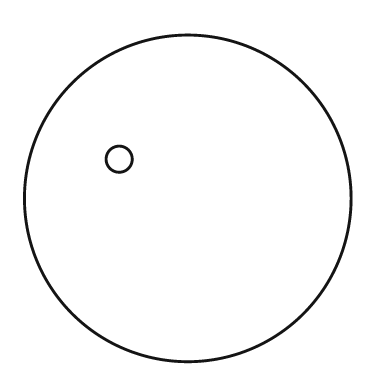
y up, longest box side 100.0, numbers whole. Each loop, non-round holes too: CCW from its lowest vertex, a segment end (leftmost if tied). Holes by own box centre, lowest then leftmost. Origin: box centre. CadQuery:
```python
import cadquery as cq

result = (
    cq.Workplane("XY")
    .moveTo(0.0, 0.0)
    .circle(50.0)
    .moveTo(-21.0, 12.0)
    .circle(4.0)
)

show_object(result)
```